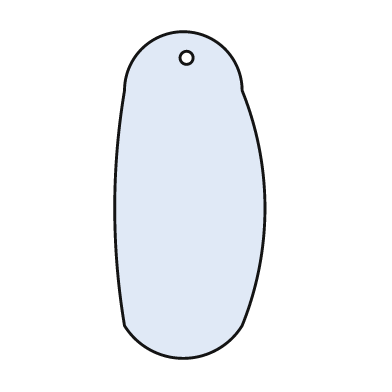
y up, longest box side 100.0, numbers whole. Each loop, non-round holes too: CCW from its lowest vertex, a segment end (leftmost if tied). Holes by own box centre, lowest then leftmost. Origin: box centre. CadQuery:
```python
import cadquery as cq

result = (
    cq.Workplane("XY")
    .moveTo(-20.0, -40.0)
    .threePointArc((-2.0, -50.0), (16.0, -40.0))
    .threePointArc((23.0, -4.0), (16.0, 32.0))
    .threePointArc((-2.0, 50.0), (-20.0, 32.0))
    .threePointArc((-23.0, -4.0), (-20.0, -40.0))
    .close()
    .moveTo(-1.0, 42.0)
    .circle(2.0)
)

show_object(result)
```